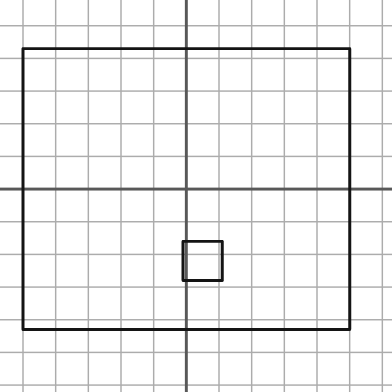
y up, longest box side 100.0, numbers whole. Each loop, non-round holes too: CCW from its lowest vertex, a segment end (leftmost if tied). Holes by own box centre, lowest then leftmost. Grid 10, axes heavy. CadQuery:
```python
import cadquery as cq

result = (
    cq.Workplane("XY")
    .moveTo(-50.0, -43.0)
    .lineTo(50.0, -43.0)
    .lineTo(50.0, 43.0)
    .lineTo(-50.0, 43.0)
    .close()
    .moveTo(-1.0, -28.0)
    .lineTo(11.0, -28.0)
    .lineTo(11.0, -16.0)
    .lineTo(-1.0, -16.0)
    .close()
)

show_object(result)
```